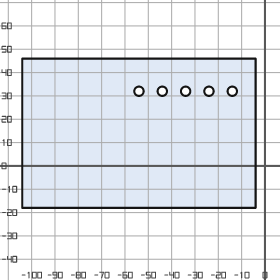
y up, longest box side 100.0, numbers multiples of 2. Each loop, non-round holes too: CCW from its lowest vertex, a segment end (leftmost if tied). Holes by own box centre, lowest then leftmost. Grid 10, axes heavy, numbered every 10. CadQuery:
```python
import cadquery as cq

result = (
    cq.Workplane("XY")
    .moveTo(-104.0, -18.0)
    .lineTo(-4.0, -18.0)
    .lineTo(-4.0, 46.0)
    .lineTo(-104.0, 46.0)
    .close()
    .moveTo(-54.0, 32.0)
    .circle(2.0)
    .moveTo(-44.0, 32.0)
    .circle(2.0)
    .moveTo(-34.0, 32.0)
    .circle(2.0)
    .moveTo(-24.0, 32.0)
    .circle(2.0)
    .moveTo(-14.0, 32.0)
    .circle(2.0)
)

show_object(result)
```